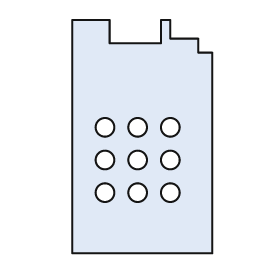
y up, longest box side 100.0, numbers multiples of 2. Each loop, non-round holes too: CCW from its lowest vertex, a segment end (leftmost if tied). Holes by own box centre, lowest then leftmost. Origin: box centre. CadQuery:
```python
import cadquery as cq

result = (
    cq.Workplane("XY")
    .moveTo(-30.0, -50.0)
    .lineTo(30.0, -50.0)
    .lineTo(30.0, 36.0)
    .lineTo(24.0, 36.0)
    .lineTo(24.0, 42.0)
    .lineTo(12.0, 42.0)
    .lineTo(12.0, 50.0)
    .lineTo(8.0, 50.0)
    .lineTo(8.0, 40.0)
    .lineTo(-14.0, 40.0)
    .lineTo(-14.0, 50.0)
    .lineTo(-30.0, 50.0)
    .close()
    .moveTo(-16.0, -24.0)
    .circle(4.0)
    .moveTo(-2.0, -24.0)
    .circle(4.0)
    .moveTo(12.0, -24.0)
    .circle(4.0)
    .moveTo(-16.0, -10.0)
    .circle(4.0)
    .moveTo(-2.0, -10.0)
    .circle(4.0)
    .moveTo(12.0, -10.0)
    .circle(4.0)
    .moveTo(-16.0, 4.0)
    .circle(4.0)
    .moveTo(-2.0, 4.0)
    .circle(4.0)
    .moveTo(12.0, 4.0)
    .circle(4.0)
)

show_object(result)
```